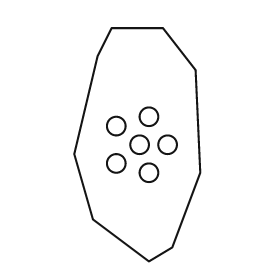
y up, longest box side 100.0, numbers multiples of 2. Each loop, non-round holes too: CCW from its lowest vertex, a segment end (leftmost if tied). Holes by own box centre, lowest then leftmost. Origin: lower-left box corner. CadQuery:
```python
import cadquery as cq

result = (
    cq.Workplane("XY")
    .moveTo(32.0, 0.0)
    .lineTo(42.0, 6.0)
    .lineTo(54.0, 38.0)
    .lineTo(52.0, 82.0)
    .lineTo(38.0, 100.0)
    .lineTo(16.0, 100.0)
    .lineTo(10.0, 88.0)
    .lineTo(0.0, 46.0)
    .lineTo(8.0, 18.0)
    .close()
    .moveTo(32.0, 38.0)
    .circle(4.0)
    .moveTo(18.0, 42.0)
    .circle(4.0)
    .moveTo(28.0, 50.0)
    .circle(4.0)
    .moveTo(40.0, 50.0)
    .circle(4.0)
    .moveTo(18.0, 58.0)
    .circle(4.0)
    .moveTo(32.0, 62.0)
    .circle(4.0)
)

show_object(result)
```